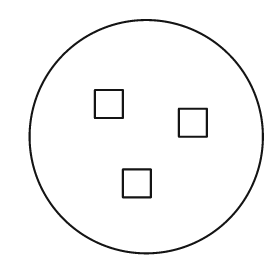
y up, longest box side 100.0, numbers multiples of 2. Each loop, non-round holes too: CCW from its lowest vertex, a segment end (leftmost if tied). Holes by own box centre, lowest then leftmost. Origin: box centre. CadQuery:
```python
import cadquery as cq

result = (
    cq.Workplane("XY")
    .moveTo(0.0, 0.0)
    .circle(50.0)
    .moveTo(-10.0, -26.0)
    .lineTo(2.0, -26.0)
    .lineTo(2.0, -14.0)
    .lineTo(-10.0, -14.0)
    .close()
    .moveTo(14.0, 0.0)
    .lineTo(26.0, 0.0)
    .lineTo(26.0, 12.0)
    .lineTo(14.0, 12.0)
    .close()
    .moveTo(-22.0, 8.0)
    .lineTo(-10.0, 8.0)
    .lineTo(-10.0, 20.0)
    .lineTo(-22.0, 20.0)
    .close()
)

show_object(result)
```